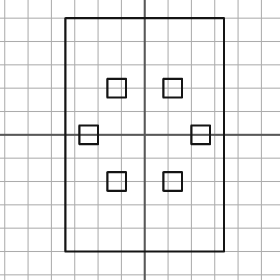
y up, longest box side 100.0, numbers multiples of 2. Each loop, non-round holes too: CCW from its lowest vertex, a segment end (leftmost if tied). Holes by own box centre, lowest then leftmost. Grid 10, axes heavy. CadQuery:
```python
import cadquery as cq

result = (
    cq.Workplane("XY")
    .moveTo(-34.0, -50.0)
    .lineTo(34.0, -50.0)
    .lineTo(34.0, 50.0)
    .lineTo(-34.0, 50.0)
    .close()
    .moveTo(-16.0, -24.0)
    .lineTo(-8.0, -24.0)
    .lineTo(-8.0, -16.0)
    .lineTo(-16.0, -16.0)
    .close()
    .moveTo(8.0, -24.0)
    .lineTo(16.0, -24.0)
    .lineTo(16.0, -16.0)
    .lineTo(8.0, -16.0)
    .close()
    .moveTo(-28.0, -4.0)
    .lineTo(-20.0, -4.0)
    .lineTo(-20.0, 4.0)
    .lineTo(-28.0, 4.0)
    .close()
    .moveTo(20.0, -4.0)
    .lineTo(28.0, -4.0)
    .lineTo(28.0, 4.0)
    .lineTo(20.0, 4.0)
    .close()
    .moveTo(-16.0, 16.0)
    .lineTo(-8.0, 16.0)
    .lineTo(-8.0, 24.0)
    .lineTo(-16.0, 24.0)
    .close()
    .moveTo(8.0, 16.0)
    .lineTo(16.0, 16.0)
    .lineTo(16.0, 24.0)
    .lineTo(8.0, 24.0)
    .close()
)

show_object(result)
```